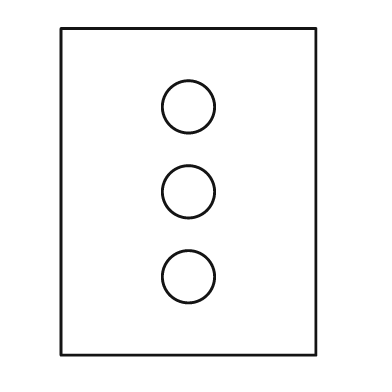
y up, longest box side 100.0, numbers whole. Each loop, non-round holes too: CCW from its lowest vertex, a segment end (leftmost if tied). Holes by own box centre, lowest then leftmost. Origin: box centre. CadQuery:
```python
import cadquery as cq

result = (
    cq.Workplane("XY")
    .moveTo(-39.0, -50.0)
    .lineTo(39.0, -50.0)
    .lineTo(39.0, 50.0)
    .lineTo(-39.0, 50.0)
    .close()
    .moveTo(0.0, -26.0)
    .circle(8.0)
    .moveTo(0.0, 0.0)
    .circle(8.0)
    .moveTo(0.0, 26.0)
    .circle(8.0)
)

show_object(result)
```